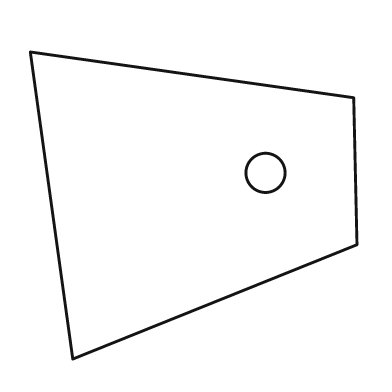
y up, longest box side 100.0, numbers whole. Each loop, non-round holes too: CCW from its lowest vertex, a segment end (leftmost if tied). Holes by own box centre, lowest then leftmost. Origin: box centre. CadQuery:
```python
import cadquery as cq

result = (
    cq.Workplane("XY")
    .moveTo(-37.0, -47.0)
    .lineTo(50.0, -12.0)
    .lineTo(49.0, 33.0)
    .lineTo(-50.0, 47.0)
    .close()
    .moveTo(22.0, 10.0)
    .circle(6.0)
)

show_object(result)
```